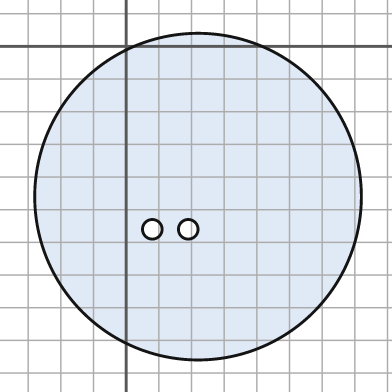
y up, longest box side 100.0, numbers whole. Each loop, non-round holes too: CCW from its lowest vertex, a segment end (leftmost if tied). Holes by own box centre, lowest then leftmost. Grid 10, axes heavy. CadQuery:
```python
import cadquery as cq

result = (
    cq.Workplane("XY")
    .moveTo(22.0, -46.0)
    .circle(50.0)
    .moveTo(8.0, -56.0)
    .circle(3.0)
    .moveTo(19.0, -56.0)
    .circle(3.0)
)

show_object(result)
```